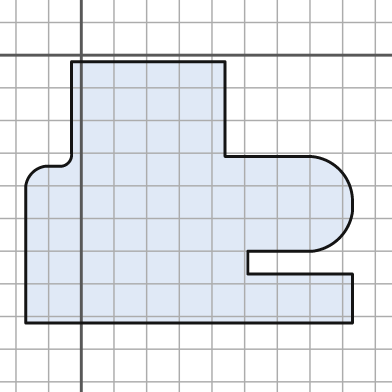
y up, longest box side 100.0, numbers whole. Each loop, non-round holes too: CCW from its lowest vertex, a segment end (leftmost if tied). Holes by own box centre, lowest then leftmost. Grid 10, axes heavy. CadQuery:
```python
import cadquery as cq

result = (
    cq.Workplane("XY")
    .moveTo(-17.0, -82.0)
    .lineTo(83.0, -82.0)
    .lineTo(83.0, -67.0)
    .lineTo(51.0, -67.0)
    .lineTo(51.0, -60.0)
    .lineTo(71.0, -60.0)
    .threePointArc((79.0, -56.0), (83.0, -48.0))
    .lineTo(83.0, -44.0)
    .threePointArc((79.0, -35.0), (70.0, -31.0))
    .lineTo(44.0, -31.0)
    .lineTo(44.0, -2.0)
    .lineTo(-3.0, -2.0)
    .lineTo(-3.0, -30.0)
    .threePointArc((-4.0, -33.0), (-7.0, -34.0))
    .lineTo(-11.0, -34.0)
    .threePointArc((-15.0, -36.0), (-17.0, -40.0))
    .close()
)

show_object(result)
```